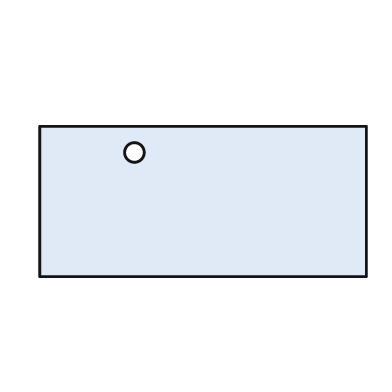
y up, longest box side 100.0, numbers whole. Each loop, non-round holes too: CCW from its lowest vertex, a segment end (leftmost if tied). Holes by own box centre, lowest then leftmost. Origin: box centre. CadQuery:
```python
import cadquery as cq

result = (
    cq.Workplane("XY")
    .moveTo(-50.0, -23.0)
    .lineTo(50.0, -23.0)
    .lineTo(50.0, 23.0)
    .lineTo(-50.0, 23.0)
    .close()
    .moveTo(-21.0, 15.0)
    .circle(3.0)
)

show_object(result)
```